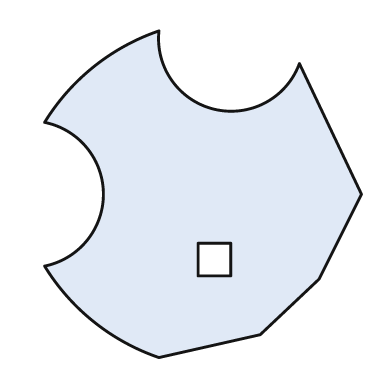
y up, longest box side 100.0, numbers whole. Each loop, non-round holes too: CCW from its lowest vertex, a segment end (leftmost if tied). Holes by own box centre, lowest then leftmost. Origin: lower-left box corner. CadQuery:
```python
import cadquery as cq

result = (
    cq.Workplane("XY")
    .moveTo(35.0, 0.0)
    .lineTo(66.0, 7.0)
    .lineTo(84.0, 24.0)
    .lineTo(97.0, 50.0)
    .lineTo(78.0, 90.0)
    .threePointArc((52.0, 76.0), (35.0, 100.0))
    .threePointArc((15.0, 89.0), (0.0, 72.0))
    .threePointArc((18.0, 50.0), (0.0, 28.0))
    .threePointArc((15.0, 11.0), (35.0, 0.0))
    .close()
    .moveTo(47.0, 25.0)
    .lineTo(57.0, 25.0)
    .lineTo(57.0, 35.0)
    .lineTo(47.0, 35.0)
    .close()
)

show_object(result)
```